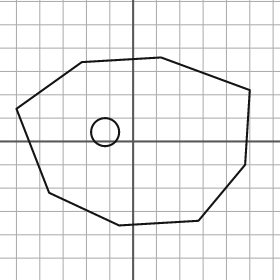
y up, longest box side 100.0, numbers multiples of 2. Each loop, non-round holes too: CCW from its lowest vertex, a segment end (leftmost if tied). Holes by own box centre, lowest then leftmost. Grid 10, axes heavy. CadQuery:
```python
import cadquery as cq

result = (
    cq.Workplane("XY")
    .moveTo(-6.0, -36.0)
    .lineTo(28.0, -34.0)
    .lineTo(48.0, -10.0)
    .lineTo(50.0, 22.0)
    .lineTo(12.0, 36.0)
    .lineTo(-22.0, 34.0)
    .lineTo(-50.0, 14.0)
    .lineTo(-36.0, -22.0)
    .close()
    .moveTo(-12.0, 4.0)
    .circle(6.0)
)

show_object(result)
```